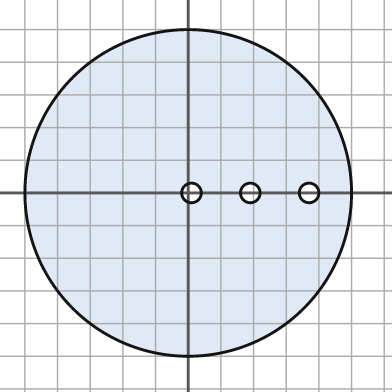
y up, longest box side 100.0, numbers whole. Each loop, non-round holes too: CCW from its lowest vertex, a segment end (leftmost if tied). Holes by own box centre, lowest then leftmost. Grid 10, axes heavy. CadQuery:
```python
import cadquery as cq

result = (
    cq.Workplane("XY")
    .moveTo(0.0, 0.0)
    .circle(50.0)
    .moveTo(1.0, 0.0)
    .circle(3.0)
    .moveTo(19.0, 0.0)
    .circle(3.0)
    .moveTo(37.0, 0.0)
    .circle(3.0)
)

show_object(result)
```